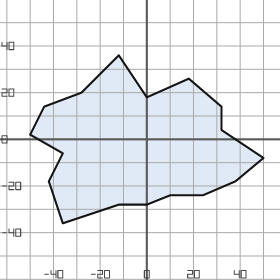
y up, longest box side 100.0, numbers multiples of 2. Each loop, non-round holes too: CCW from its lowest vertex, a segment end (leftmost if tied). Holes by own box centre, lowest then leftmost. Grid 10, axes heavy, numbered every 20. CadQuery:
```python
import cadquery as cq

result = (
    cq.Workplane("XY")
    .moveTo(-36.0, -36.0)
    .lineTo(-12.0, -28.0)
    .lineTo(0.0, -28.0)
    .lineTo(10.0, -24.0)
    .lineTo(24.0, -24.0)
    .lineTo(38.0, -18.0)
    .lineTo(50.0, -8.0)
    .lineTo(32.0, 4.0)
    .lineTo(32.0, 14.0)
    .lineTo(18.0, 26.0)
    .lineTo(0.0, 18.0)
    .lineTo(-12.0, 36.0)
    .lineTo(-28.0, 20.0)
    .lineTo(-44.0, 14.0)
    .lineTo(-50.0, 2.0)
    .lineTo(-36.0, -6.0)
    .lineTo(-42.0, -18.0)
    .close()
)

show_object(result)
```